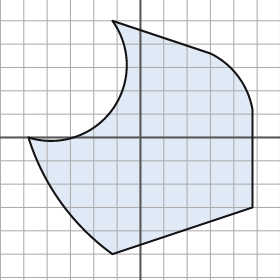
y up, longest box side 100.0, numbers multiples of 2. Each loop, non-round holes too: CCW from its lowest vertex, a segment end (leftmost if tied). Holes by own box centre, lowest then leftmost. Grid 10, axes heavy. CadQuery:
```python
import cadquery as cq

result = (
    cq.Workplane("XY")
    .moveTo(-12.0, -50.0)
    .lineTo(48.0, -30.0)
    .lineTo(48.0, 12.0)
    .threePointArc((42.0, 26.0), (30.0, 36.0))
    .lineTo(-12.0, 50.0)
    .threePointArc((-12.0, 12.0), (-48.0, 0.0))
    .threePointArc((-34.0, -28.0), (-12.0, -50.0))
    .close()
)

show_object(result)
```